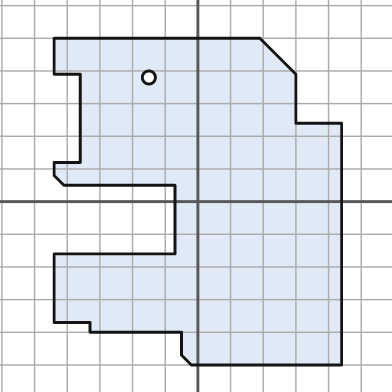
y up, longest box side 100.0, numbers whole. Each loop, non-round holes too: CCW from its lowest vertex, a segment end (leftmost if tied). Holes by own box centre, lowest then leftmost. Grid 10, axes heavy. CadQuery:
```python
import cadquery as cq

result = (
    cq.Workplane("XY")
    .moveTo(-2.0, -50.0)
    .lineTo(44.0, -50.0)
    .lineTo(44.0, 24.0)
    .lineTo(30.0, 24.0)
    .lineTo(30.0, 39.0)
    .lineTo(19.0, 50.0)
    .lineTo(-44.0, 50.0)
    .lineTo(-44.0, 39.0)
    .lineTo(-36.0, 39.0)
    .lineTo(-36.0, 12.0)
    .lineTo(-44.0, 12.0)
    .lineTo(-44.0, 8.0)
    .lineTo(-41.0, 5.0)
    .lineTo(-7.0, 5.0)
    .lineTo(-7.0, -16.0)
    .lineTo(-44.0, -16.0)
    .lineTo(-44.0, -37.0)
    .lineTo(-33.0, -37.0)
    .lineTo(-33.0, -40.0)
    .lineTo(-5.0, -40.0)
    .lineTo(-5.0, -47.0)
    .close()
    .moveTo(-15.0, 38.0)
    .circle(2.0)
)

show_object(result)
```